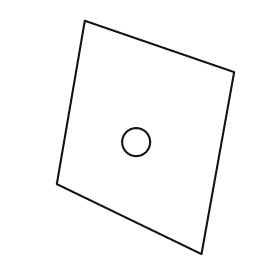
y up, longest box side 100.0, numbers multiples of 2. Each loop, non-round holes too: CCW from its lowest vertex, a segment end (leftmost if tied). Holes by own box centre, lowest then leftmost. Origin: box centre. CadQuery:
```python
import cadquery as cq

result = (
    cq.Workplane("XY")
    .moveTo(24.0, -50.0)
    .lineTo(38.0, 28.0)
    .lineTo(-26.0, 50.0)
    .lineTo(-38.0, -20.0)
    .close()
    .moveTo(-4.0, -2.0)
    .circle(6.0)
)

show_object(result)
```